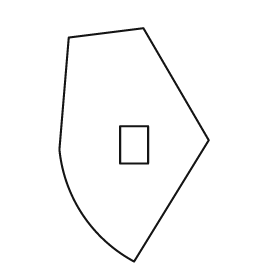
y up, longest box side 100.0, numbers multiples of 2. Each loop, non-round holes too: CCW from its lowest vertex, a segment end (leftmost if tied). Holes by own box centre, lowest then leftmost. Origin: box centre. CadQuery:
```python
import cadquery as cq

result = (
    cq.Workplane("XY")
    .moveTo(0.0, -50.0)
    .lineTo(32.0, 2.0)
    .lineTo(4.0, 50.0)
    .lineTo(-28.0, 46.0)
    .lineTo(-32.0, -2.0)
    .threePointArc((-22.0, -30.0), (0.0, -50.0))
    .close()
    .moveTo(-6.0, -8.0)
    .lineTo(6.0, -8.0)
    .lineTo(6.0, 8.0)
    .lineTo(-6.0, 8.0)
    .close()
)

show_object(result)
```